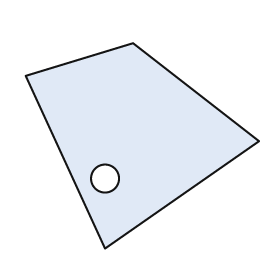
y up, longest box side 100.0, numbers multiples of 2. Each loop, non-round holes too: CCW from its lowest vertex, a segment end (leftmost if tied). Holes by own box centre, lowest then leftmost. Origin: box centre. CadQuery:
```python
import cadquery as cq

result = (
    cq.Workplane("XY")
    .moveTo(-16.0, -44.0)
    .lineTo(50.0, 2.0)
    .lineTo(-4.0, 44.0)
    .lineTo(-50.0, 30.0)
    .close()
    .moveTo(-16.0, -14.0)
    .circle(6.0)
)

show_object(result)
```